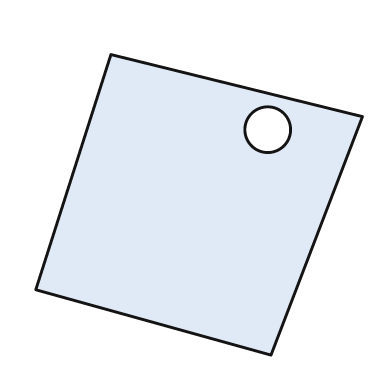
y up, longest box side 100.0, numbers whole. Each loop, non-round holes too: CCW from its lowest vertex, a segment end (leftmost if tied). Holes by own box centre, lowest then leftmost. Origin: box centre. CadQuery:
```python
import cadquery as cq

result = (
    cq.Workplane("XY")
    .moveTo(22.0, -46.0)
    .lineTo(50.0, 27.0)
    .lineTo(-27.0, 46.0)
    .lineTo(-50.0, -26.0)
    .close()
    .moveTo(21.0, 23.0)
    .circle(7.0)
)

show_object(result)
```